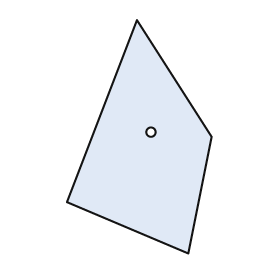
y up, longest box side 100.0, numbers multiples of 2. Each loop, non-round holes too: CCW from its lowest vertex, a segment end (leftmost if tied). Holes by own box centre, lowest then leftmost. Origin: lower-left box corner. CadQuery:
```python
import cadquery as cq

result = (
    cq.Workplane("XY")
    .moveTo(52.0, 0.0)
    .lineTo(62.0, 50.0)
    .lineTo(30.0, 100.0)
    .lineTo(0.0, 22.0)
    .close()
    .moveTo(36.0, 52.0)
    .circle(2.0)
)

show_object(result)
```